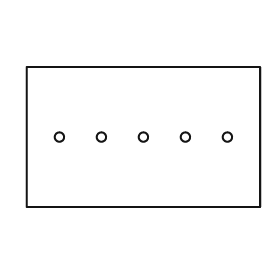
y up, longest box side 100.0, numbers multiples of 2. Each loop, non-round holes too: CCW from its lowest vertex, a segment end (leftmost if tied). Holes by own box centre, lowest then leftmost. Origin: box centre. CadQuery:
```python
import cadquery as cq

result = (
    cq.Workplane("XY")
    .moveTo(-50.0, -30.0)
    .lineTo(50.0, -30.0)
    .lineTo(50.0, 30.0)
    .lineTo(-50.0, 30.0)
    .close()
    .moveTo(-36.0, 0.0)
    .circle(2.0)
    .moveTo(-18.0, 0.0)
    .circle(2.0)
    .moveTo(0.0, 0.0)
    .circle(2.0)
    .moveTo(18.0, 0.0)
    .circle(2.0)
    .moveTo(36.0, 0.0)
    .circle(2.0)
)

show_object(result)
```